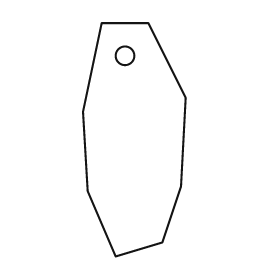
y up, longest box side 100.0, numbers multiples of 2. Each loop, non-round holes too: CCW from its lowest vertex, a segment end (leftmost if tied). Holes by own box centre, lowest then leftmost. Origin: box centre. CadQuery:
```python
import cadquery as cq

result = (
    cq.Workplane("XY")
    .moveTo(-8.0, -50.0)
    .lineTo(12.0, -44.0)
    .lineTo(20.0, -20.0)
    .lineTo(22.0, 18.0)
    .lineTo(6.0, 50.0)
    .lineTo(-14.0, 50.0)
    .lineTo(-22.0, 12.0)
    .lineTo(-20.0, -22.0)
    .close()
    .moveTo(-4.0, 36.0)
    .circle(4.0)
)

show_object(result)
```